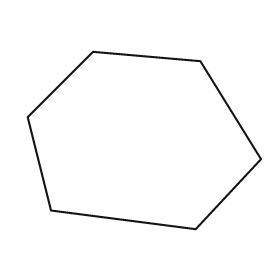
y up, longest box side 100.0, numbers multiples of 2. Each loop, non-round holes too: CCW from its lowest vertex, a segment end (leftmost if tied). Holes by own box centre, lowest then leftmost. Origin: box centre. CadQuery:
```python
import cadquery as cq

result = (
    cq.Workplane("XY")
    .moveTo(22.0, -38.0)
    .lineTo(50.0, -8.0)
    .lineTo(24.0, 34.0)
    .lineTo(-22.0, 38.0)
    .lineTo(-50.0, 10.0)
    .lineTo(-40.0, -30.0)
    .close()
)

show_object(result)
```